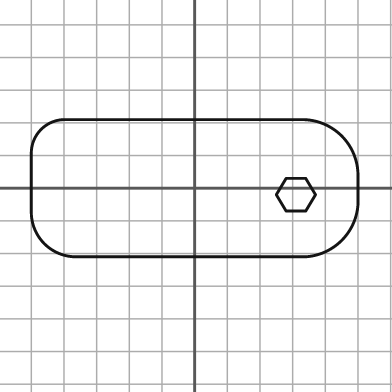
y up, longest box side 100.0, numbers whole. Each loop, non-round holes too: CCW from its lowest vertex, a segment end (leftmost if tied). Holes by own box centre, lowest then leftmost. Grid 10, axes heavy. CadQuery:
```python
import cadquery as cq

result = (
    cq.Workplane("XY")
    .moveTo(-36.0, -21.0)
    .lineTo(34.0, -21.0)
    .threePointArc((45.0, -16.0), (50.0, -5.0))
    .lineTo(50.0, 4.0)
    .threePointArc((45.0, 16.0), (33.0, 21.0))
    .lineTo(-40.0, 21.0)
    .threePointArc((-47.0, 18.0), (-50.0, 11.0))
    .lineTo(-50.0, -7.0)
    .threePointArc((-46.0, -17.0), (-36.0, -21.0))
    .close()
    .moveTo(28.0, -7.0)
    .lineTo(34.0, -7.0)
    .lineTo(37.0, -2.0)
    .lineTo(34.0, 3.0)
    .lineTo(28.0, 3.0)
    .lineTo(25.0, -2.0)
    .close()
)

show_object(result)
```